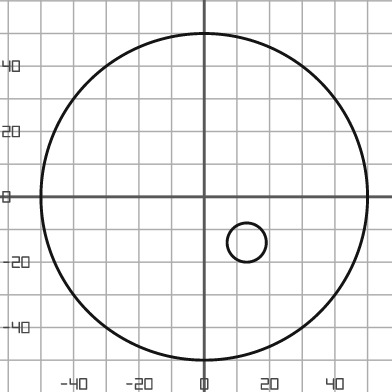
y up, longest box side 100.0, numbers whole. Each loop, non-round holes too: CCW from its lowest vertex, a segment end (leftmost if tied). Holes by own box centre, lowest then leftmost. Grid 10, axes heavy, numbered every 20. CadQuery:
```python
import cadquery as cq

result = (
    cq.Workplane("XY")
    .moveTo(0.0, 0.0)
    .circle(50.0)
    .moveTo(13.0, -14.0)
    .circle(6.0)
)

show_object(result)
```